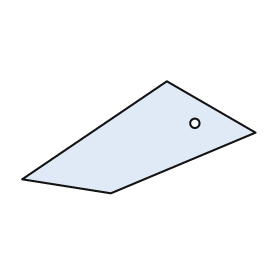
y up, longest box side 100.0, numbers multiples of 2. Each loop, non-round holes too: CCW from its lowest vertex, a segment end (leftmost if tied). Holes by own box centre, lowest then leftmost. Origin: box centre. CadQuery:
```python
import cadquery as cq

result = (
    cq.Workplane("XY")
    .moveTo(-12.0, -24.0)
    .lineTo(50.0, 2.0)
    .lineTo(12.0, 24.0)
    .lineTo(-50.0, -18.0)
    .close()
    .moveTo(24.0, 6.0)
    .circle(2.0)
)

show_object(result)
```